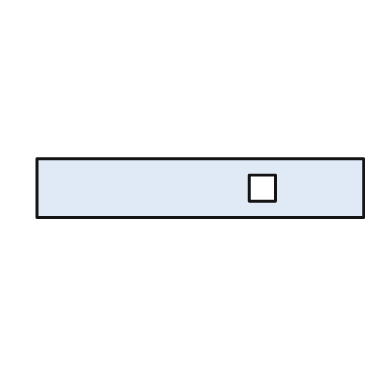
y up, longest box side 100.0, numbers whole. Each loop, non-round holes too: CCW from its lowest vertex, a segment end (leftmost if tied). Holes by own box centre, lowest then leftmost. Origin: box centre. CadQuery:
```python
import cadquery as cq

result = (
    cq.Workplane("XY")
    .moveTo(-50.0, -9.0)
    .lineTo(50.0, -9.0)
    .lineTo(50.0, 9.0)
    .lineTo(-50.0, 9.0)
    .close()
    .moveTo(15.0, -4.0)
    .lineTo(23.0, -4.0)
    .lineTo(23.0, 4.0)
    .lineTo(15.0, 4.0)
    .close()
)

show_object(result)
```